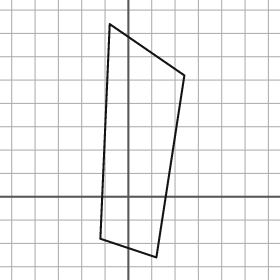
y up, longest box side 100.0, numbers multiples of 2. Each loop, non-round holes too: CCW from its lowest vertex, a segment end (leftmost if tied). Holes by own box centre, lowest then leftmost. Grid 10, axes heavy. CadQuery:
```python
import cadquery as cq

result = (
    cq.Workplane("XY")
    .moveTo(12.0, -26.0)
    .lineTo(24.0, 52.0)
    .lineTo(-8.0, 74.0)
    .lineTo(-12.0, -18.0)
    .close()
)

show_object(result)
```